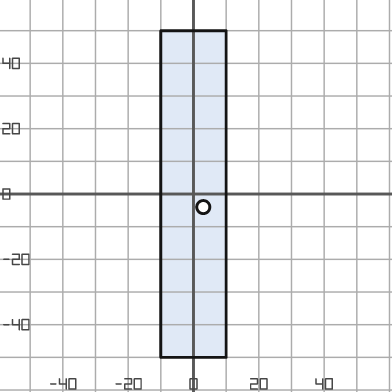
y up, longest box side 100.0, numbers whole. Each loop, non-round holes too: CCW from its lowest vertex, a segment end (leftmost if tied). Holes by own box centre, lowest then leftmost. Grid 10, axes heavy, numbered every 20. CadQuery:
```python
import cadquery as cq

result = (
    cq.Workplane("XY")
    .moveTo(-10.0, -50.0)
    .lineTo(10.0, -50.0)
    .lineTo(10.0, 50.0)
    .lineTo(-10.0, 50.0)
    .close()
    .moveTo(3.0, -4.0)
    .circle(2.0)
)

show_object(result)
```